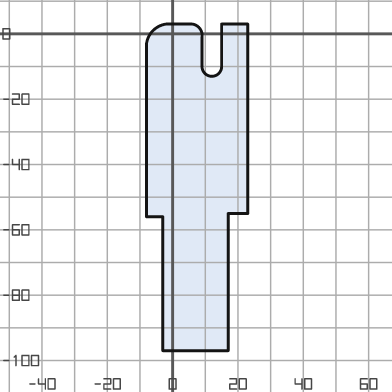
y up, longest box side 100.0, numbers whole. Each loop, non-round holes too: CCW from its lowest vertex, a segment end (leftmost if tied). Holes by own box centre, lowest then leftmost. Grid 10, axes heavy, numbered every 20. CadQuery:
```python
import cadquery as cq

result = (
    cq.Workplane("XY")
    .moveTo(-3.0, -97.0)
    .lineTo(17.0, -97.0)
    .lineTo(17.0, -55.0)
    .lineTo(23.0, -55.0)
    .lineTo(23.0, 3.0)
    .lineTo(15.0, 3.0)
    .lineTo(15.0, -10.0)
    .threePointArc((12.0, -13.0), (9.0, -10.0))
    .lineTo(9.0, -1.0)
    .threePointArc((8.0, 2.0), (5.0, 3.0))
    .lineTo(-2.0, 3.0)
    .threePointArc((-6.0, 1.0), (-8.0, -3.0))
    .lineTo(-8.0, -56.0)
    .lineTo(-3.0, -56.0)
    .close()
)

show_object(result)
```